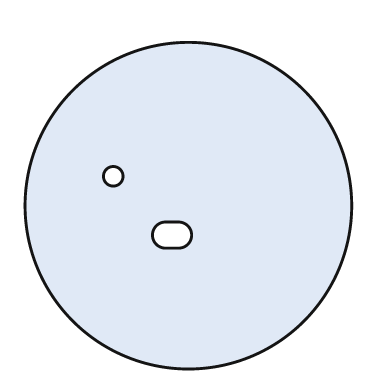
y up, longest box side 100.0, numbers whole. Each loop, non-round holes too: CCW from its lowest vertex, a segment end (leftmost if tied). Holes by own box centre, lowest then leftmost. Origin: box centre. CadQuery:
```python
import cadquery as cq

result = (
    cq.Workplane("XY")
    .moveTo(0.0, 0.0)
    .circle(50.0)
    .moveTo(-7.0, -13.0)
    .lineTo(-3.0, -13.0)
    .threePointArc((1.0, -9.0), (-3.0, -5.0))
    .lineTo(-7.0, -5.0)
    .threePointArc((-11.0, -9.0), (-7.0, -13.0))
    .close()
    .moveTo(-23.0, 9.0)
    .circle(3.0)
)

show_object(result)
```